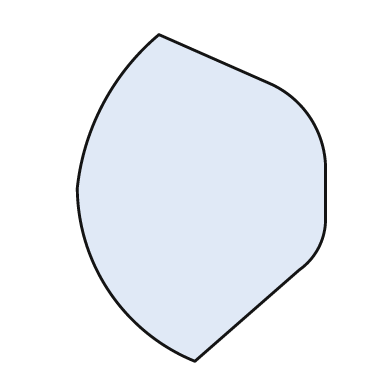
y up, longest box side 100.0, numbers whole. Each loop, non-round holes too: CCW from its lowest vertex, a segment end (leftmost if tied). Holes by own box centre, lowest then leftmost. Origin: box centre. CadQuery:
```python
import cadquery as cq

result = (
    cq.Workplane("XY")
    .moveTo(-2.0, -50.0)
    .lineTo(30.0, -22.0)
    .threePointArc((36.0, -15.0), (38.0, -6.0))
    .lineTo(38.0, 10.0)
    .threePointArc((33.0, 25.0), (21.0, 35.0))
    .lineTo(-13.0, 50.0)
    .threePointArc((-30.0, 29.0), (-38.0, 3.0))
    .threePointArc((-28.0, -29.0), (-2.0, -50.0))
    .close()
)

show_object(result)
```